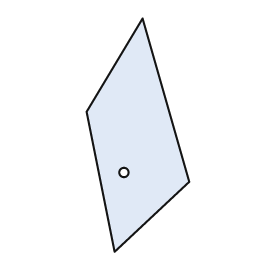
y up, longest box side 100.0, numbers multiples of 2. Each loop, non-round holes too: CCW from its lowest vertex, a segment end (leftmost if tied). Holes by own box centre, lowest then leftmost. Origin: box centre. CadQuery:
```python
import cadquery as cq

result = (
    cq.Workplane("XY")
    .moveTo(-10.0, -50.0)
    .lineTo(22.0, -20.0)
    .lineTo(2.0, 50.0)
    .lineTo(-22.0, 10.0)
    .close()
    .moveTo(-6.0, -16.0)
    .circle(2.0)
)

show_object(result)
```